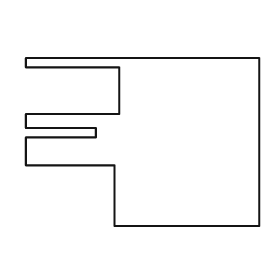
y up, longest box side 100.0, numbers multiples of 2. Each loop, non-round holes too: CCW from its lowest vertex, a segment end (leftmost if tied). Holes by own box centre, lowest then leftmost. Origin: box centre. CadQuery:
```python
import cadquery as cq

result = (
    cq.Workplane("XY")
    .moveTo(-12.0, -36.0)
    .lineTo(50.0, -36.0)
    .lineTo(50.0, 36.0)
    .lineTo(-50.0, 36.0)
    .lineTo(-50.0, 32.0)
    .lineTo(-10.0, 32.0)
    .lineTo(-10.0, 12.0)
    .lineTo(-50.0, 12.0)
    .lineTo(-50.0, 6.0)
    .lineTo(-20.0, 6.0)
    .lineTo(-20.0, 2.0)
    .lineTo(-50.0, 2.0)
    .lineTo(-50.0, -10.0)
    .lineTo(-12.0, -10.0)
    .close()
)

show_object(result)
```